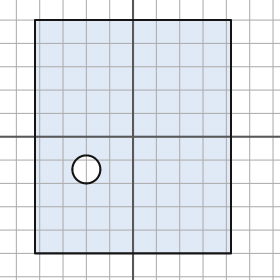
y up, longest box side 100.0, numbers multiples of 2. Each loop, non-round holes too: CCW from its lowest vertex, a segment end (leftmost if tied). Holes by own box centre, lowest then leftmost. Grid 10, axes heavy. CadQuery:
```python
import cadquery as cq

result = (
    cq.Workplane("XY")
    .moveTo(-42.0, -50.0)
    .lineTo(42.0, -50.0)
    .lineTo(42.0, 50.0)
    .lineTo(-42.0, 50.0)
    .close()
    .moveTo(-20.0, -14.0)
    .circle(6.0)
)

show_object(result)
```